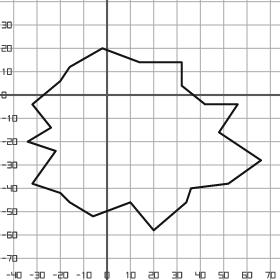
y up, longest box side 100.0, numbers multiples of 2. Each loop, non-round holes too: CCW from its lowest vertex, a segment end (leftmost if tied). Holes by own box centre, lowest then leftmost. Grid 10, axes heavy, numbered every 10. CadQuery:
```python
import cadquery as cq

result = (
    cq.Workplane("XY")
    .moveTo(20.0, -58.0)
    .lineTo(34.0, -46.0)
    .lineTo(36.0, -40.0)
    .lineTo(52.0, -38.0)
    .lineTo(66.0, -28.0)
    .lineTo(48.0, -16.0)
    .lineTo(56.0, -4.0)
    .lineTo(42.0, -4.0)
    .lineTo(32.0, 4.0)
    .lineTo(32.0, 14.0)
    .lineTo(14.0, 14.0)
    .lineTo(-2.0, 20.0)
    .lineTo(-16.0, 12.0)
    .lineTo(-20.0, 6.0)
    .lineTo(-32.0, -4.0)
    .lineTo(-24.0, -14.0)
    .lineTo(-34.0, -20.0)
    .lineTo(-22.0, -24.0)
    .lineTo(-32.0, -38.0)
    .lineTo(-20.0, -42.0)
    .lineTo(-16.0, -46.0)
    .lineTo(-6.0, -52.0)
    .lineTo(10.0, -46.0)
    .close()
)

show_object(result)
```